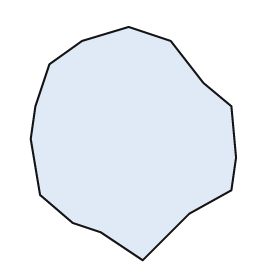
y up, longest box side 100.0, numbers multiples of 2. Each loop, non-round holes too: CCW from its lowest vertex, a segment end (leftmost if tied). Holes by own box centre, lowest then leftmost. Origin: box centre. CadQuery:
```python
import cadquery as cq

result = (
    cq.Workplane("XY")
    .moveTo(4.0, -50.0)
    .lineTo(24.0, -30.0)
    .lineTo(42.0, -20.0)
    .lineTo(44.0, -6.0)
    .lineTo(42.0, 16.0)
    .lineTo(30.0, 26.0)
    .lineTo(16.0, 44.0)
    .lineTo(-2.0, 50.0)
    .lineTo(-22.0, 44.0)
    .lineTo(-36.0, 34.0)
    .lineTo(-42.0, 16.0)
    .lineTo(-44.0, 2.0)
    .lineTo(-40.0, -22.0)
    .lineTo(-26.0, -34.0)
    .lineTo(-14.0, -38.0)
    .close()
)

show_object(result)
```